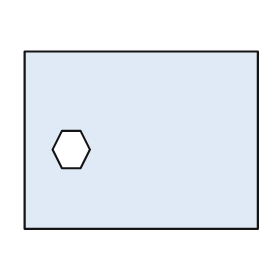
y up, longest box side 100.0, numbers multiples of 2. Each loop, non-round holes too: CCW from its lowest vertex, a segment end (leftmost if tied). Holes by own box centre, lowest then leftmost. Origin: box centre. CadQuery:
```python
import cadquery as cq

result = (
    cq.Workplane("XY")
    .moveTo(-50.0, -38.0)
    .lineTo(50.0, -38.0)
    .lineTo(50.0, 38.0)
    .lineTo(-50.0, 38.0)
    .close()
    .moveTo(-34.0, -12.0)
    .lineTo(-26.0, -12.0)
    .lineTo(-22.0, -4.0)
    .lineTo(-26.0, 4.0)
    .lineTo(-34.0, 4.0)
    .lineTo(-38.0, -4.0)
    .close()
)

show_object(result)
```